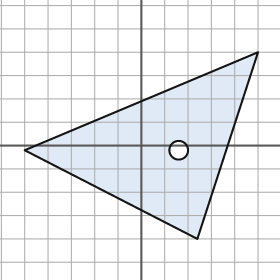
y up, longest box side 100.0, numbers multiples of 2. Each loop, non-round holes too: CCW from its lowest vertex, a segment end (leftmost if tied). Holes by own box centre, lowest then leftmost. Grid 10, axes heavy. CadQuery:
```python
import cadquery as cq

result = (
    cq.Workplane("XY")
    .moveTo(24.0, -40.0)
    .lineTo(50.0, 40.0)
    .lineTo(-50.0, -2.0)
    .close()
    .moveTo(16.0, -2.0)
    .circle(4.0)
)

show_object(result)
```